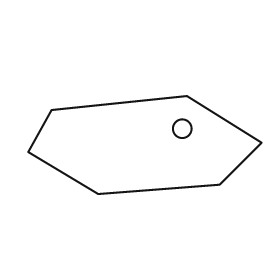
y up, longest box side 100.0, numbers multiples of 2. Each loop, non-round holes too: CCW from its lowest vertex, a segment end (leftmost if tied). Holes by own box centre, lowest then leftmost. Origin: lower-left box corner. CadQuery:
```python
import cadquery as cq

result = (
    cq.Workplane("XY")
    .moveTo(30.0, 0.0)
    .lineTo(82.0, 4.0)
    .lineTo(100.0, 22.0)
    .lineTo(68.0, 42.0)
    .lineTo(10.0, 36.0)
    .lineTo(0.0, 18.0)
    .close()
    .moveTo(66.0, 28.0)
    .circle(4.0)
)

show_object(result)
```